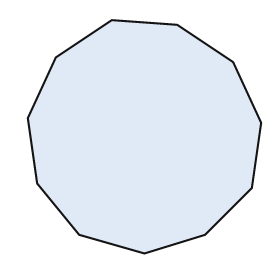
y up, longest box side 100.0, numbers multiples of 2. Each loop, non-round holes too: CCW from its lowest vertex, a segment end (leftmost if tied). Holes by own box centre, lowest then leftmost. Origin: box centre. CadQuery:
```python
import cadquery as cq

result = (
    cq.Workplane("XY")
    .moveTo(0.0, -50.0)
    .lineTo(26.0, -42.0)
    .lineTo(46.0, -22.0)
    .lineTo(50.0, 6.0)
    .lineTo(38.0, 32.0)
    .lineTo(14.0, 48.0)
    .lineTo(-14.0, 50.0)
    .lineTo(-38.0, 34.0)
    .lineTo(-50.0, 8.0)
    .lineTo(-46.0, -20.0)
    .lineTo(-28.0, -42.0)
    .close()
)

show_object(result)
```